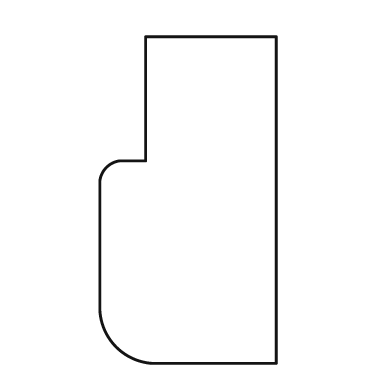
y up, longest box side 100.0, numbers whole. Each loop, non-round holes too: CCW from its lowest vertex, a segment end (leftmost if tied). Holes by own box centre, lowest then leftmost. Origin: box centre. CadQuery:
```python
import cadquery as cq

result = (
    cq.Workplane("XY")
    .moveTo(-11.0, -50.0)
    .lineTo(27.0, -50.0)
    .lineTo(27.0, 50.0)
    .lineTo(-13.0, 50.0)
    .lineTo(-13.0, 12.0)
    .lineTo(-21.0, 12.0)
    .threePointArc((-25.0, 10.0), (-27.0, 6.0))
    .lineTo(-27.0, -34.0)
    .threePointArc((-22.0, -45.0), (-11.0, -50.0))
    .close()
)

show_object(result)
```